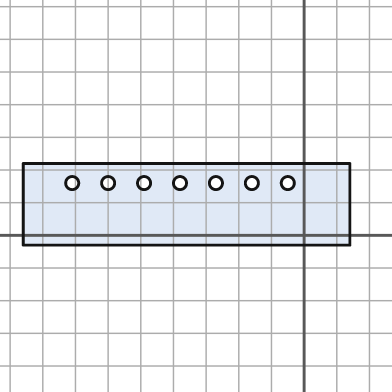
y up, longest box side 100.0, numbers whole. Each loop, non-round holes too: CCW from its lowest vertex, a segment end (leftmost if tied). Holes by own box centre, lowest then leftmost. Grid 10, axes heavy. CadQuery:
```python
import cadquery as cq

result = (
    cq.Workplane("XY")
    .moveTo(-86.0, -3.0)
    .lineTo(14.0, -3.0)
    .lineTo(14.0, 22.0)
    .lineTo(-86.0, 22.0)
    .close()
    .moveTo(-71.0, 16.0)
    .circle(2.0)
    .moveTo(-60.0, 16.0)
    .circle(2.0)
    .moveTo(-49.0, 16.0)
    .circle(2.0)
    .moveTo(-38.0, 16.0)
    .circle(2.0)
    .moveTo(-27.0, 16.0)
    .circle(2.0)
    .moveTo(-16.0, 16.0)
    .circle(2.0)
    .moveTo(-5.0, 16.0)
    .circle(2.0)
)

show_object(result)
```